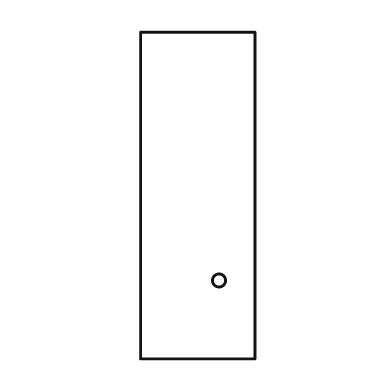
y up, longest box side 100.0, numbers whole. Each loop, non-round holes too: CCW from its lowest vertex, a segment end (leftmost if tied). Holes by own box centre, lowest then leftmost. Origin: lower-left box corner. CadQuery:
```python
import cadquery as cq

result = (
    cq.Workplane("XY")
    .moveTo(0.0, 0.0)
    .lineTo(35.0, 0.0)
    .lineTo(35.0, 100.0)
    .lineTo(0.0, 100.0)
    .close()
    .moveTo(24.0, 24.0)
    .circle(2.0)
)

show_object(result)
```